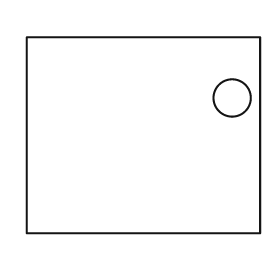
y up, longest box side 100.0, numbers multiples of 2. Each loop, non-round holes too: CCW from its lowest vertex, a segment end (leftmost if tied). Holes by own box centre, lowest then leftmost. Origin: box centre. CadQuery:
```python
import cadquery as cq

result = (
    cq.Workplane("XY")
    .moveTo(-50.0, -42.0)
    .lineTo(50.0, -42.0)
    .lineTo(50.0, 42.0)
    .lineTo(-50.0, 42.0)
    .close()
    .moveTo(38.0, 16.0)
    .circle(8.0)
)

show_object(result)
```